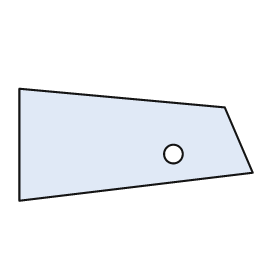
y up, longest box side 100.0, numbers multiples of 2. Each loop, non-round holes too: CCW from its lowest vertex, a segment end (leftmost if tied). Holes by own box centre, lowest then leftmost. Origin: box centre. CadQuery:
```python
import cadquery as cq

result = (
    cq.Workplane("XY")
    .moveTo(-50.0, -24.0)
    .lineTo(50.0, -12.0)
    .lineTo(38.0, 16.0)
    .lineTo(-50.0, 24.0)
    .close()
    .moveTo(16.0, -4.0)
    .circle(4.0)
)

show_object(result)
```